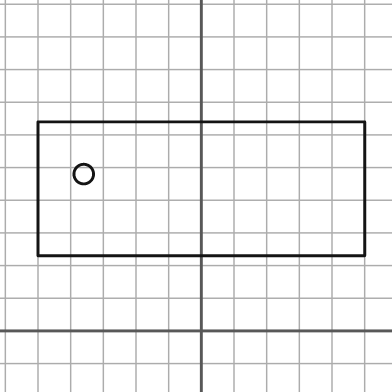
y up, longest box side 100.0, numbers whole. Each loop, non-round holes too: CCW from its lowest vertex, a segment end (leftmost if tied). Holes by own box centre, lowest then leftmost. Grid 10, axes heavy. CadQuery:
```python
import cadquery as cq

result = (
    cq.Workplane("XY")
    .moveTo(-50.0, 23.0)
    .lineTo(50.0, 23.0)
    .lineTo(50.0, 64.0)
    .lineTo(-50.0, 64.0)
    .close()
    .moveTo(-36.0, 48.0)
    .circle(3.0)
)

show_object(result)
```